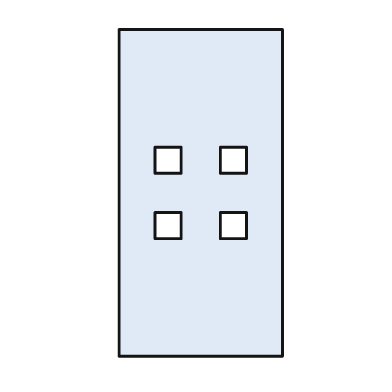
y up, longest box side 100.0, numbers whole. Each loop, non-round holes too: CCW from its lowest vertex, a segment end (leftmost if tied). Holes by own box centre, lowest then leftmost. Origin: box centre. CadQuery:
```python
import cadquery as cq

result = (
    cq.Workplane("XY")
    .moveTo(-25.0, -50.0)
    .lineTo(25.0, -50.0)
    .lineTo(25.0, 50.0)
    .lineTo(-25.0, 50.0)
    .close()
    .moveTo(-14.0, -14.0)
    .lineTo(-6.0, -14.0)
    .lineTo(-6.0, -6.0)
    .lineTo(-14.0, -6.0)
    .close()
    .moveTo(6.0, -14.0)
    .lineTo(14.0, -14.0)
    .lineTo(14.0, -6.0)
    .lineTo(6.0, -6.0)
    .close()
    .moveTo(-14.0, 6.0)
    .lineTo(-6.0, 6.0)
    .lineTo(-6.0, 14.0)
    .lineTo(-14.0, 14.0)
    .close()
    .moveTo(6.0, 6.0)
    .lineTo(14.0, 6.0)
    .lineTo(14.0, 14.0)
    .lineTo(6.0, 14.0)
    .close()
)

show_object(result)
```